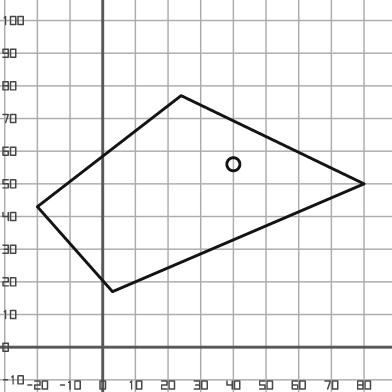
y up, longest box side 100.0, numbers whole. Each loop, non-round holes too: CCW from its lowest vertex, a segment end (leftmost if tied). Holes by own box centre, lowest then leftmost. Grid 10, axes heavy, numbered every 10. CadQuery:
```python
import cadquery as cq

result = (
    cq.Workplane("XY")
    .moveTo(3.0, 17.0)
    .lineTo(80.0, 50.0)
    .lineTo(24.0, 77.0)
    .lineTo(-20.0, 43.0)
    .close()
    .moveTo(40.0, 56.0)
    .circle(2.0)
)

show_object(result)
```